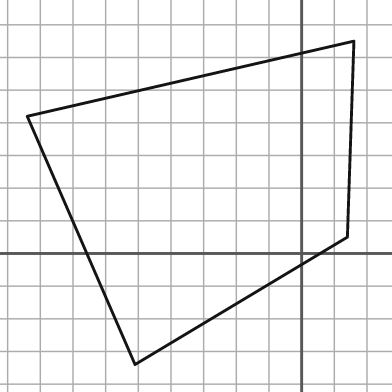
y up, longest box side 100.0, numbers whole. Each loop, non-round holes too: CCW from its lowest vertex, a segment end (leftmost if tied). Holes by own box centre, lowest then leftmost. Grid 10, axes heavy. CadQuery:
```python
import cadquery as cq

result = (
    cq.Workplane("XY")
    .moveTo(-51.0, -34.0)
    .lineTo(14.0, 5.0)
    .lineTo(16.0, 65.0)
    .lineTo(-84.0, 42.0)
    .close()
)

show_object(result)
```